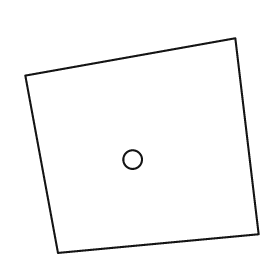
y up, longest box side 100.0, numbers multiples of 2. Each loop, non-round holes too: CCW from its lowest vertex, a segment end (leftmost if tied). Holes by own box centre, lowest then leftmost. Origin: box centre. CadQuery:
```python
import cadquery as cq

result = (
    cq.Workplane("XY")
    .moveTo(-36.0, -46.0)
    .lineTo(50.0, -38.0)
    .lineTo(40.0, 46.0)
    .lineTo(-50.0, 30.0)
    .close()
    .moveTo(-4.0, -6.0)
    .circle(4.0)
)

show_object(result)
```